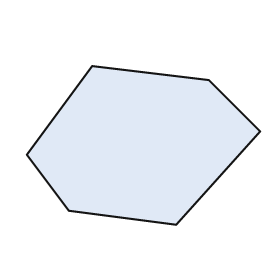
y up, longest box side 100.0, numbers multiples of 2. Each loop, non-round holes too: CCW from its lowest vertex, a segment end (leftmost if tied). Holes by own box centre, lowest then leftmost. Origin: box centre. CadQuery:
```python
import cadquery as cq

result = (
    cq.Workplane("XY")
    .moveTo(14.0, -34.0)
    .lineTo(50.0, 6.0)
    .lineTo(28.0, 28.0)
    .lineTo(-22.0, 34.0)
    .lineTo(-50.0, -4.0)
    .lineTo(-32.0, -28.0)
    .close()
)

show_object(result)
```